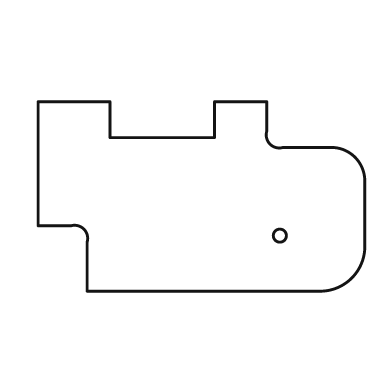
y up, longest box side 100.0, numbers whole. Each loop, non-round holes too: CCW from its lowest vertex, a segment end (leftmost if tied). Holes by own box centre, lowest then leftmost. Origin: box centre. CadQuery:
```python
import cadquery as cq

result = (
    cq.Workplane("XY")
    .moveTo(-35.0, -29.0)
    .lineTo(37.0, -29.0)
    .threePointArc((46.0, -25.0), (50.0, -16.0))
    .lineTo(50.0, 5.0)
    .threePointArc((47.0, 12.0), (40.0, 15.0))
    .lineTo(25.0, 15.0)
    .threePointArc((21.0, 16.0), (20.0, 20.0))
    .lineTo(20.0, 29.0)
    .lineTo(4.0, 29.0)
    .lineTo(4.0, 18.0)
    .lineTo(-28.0, 18.0)
    .lineTo(-28.0, 29.0)
    .lineTo(-50.0, 29.0)
    .lineTo(-50.0, -9.0)
    .lineTo(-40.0, -9.0)
    .threePointArc((-36.0, -10.0), (-35.0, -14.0))
    .close()
    .moveTo(24.0, -12.0)
    .circle(2.0)
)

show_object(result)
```